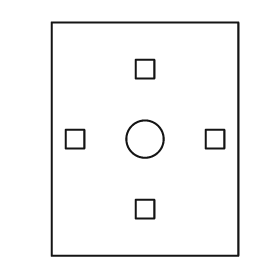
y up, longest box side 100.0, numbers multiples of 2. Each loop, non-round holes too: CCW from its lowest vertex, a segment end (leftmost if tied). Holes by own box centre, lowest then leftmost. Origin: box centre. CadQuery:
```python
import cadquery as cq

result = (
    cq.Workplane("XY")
    .moveTo(-40.0, -50.0)
    .lineTo(40.0, -50.0)
    .lineTo(40.0, 50.0)
    .lineTo(-40.0, 50.0)
    .close()
    .moveTo(-4.0, -34.0)
    .lineTo(4.0, -34.0)
    .lineTo(4.0, -26.0)
    .lineTo(-4.0, -26.0)
    .close()
    .moveTo(-34.0, -4.0)
    .lineTo(-26.0, -4.0)
    .lineTo(-26.0, 4.0)
    .lineTo(-34.0, 4.0)
    .close()
    .moveTo(0.0, 0.0)
    .circle(8.0)
    .moveTo(26.0, -4.0)
    .lineTo(34.0, -4.0)
    .lineTo(34.0, 4.0)
    .lineTo(26.0, 4.0)
    .close()
    .moveTo(-4.0, 26.0)
    .lineTo(4.0, 26.0)
    .lineTo(4.0, 34.0)
    .lineTo(-4.0, 34.0)
    .close()
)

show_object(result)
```